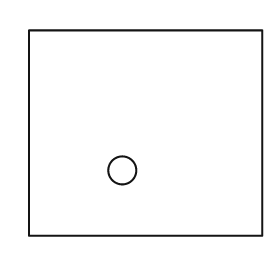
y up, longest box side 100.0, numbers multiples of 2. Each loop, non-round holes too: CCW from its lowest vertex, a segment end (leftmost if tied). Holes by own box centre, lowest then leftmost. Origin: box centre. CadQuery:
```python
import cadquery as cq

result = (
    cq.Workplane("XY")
    .moveTo(-50.0, -44.0)
    .lineTo(50.0, -44.0)
    .lineTo(50.0, 44.0)
    .lineTo(-50.0, 44.0)
    .close()
    .moveTo(-10.0, -16.0)
    .circle(6.0)
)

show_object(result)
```